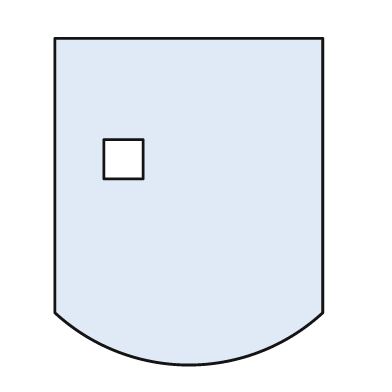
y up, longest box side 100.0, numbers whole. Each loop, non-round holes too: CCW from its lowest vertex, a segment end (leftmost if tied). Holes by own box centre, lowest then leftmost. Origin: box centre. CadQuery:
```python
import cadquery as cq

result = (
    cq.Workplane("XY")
    .moveTo(-41.0, -34.0)
    .threePointArc((0.0, -50.0), (41.0, -34.0))
    .lineTo(41.0, 50.0)
    .lineTo(-41.0, 50.0)
    .close()
    .moveTo(-26.0, 7.0)
    .lineTo(-14.0, 7.0)
    .lineTo(-14.0, 19.0)
    .lineTo(-26.0, 19.0)
    .close()
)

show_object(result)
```